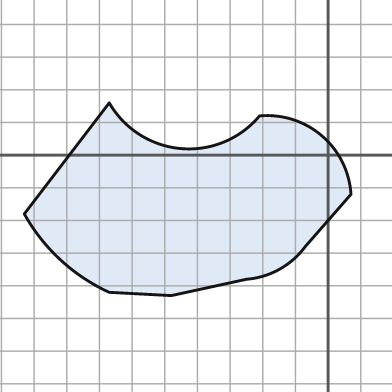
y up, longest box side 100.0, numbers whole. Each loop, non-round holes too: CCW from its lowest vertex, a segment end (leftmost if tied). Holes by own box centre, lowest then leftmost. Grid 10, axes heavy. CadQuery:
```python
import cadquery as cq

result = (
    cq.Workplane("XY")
    .moveTo(-48.0, -43.0)
    .lineTo(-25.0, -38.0)
    .threePointArc((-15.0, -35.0), (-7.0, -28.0))
    .lineTo(7.0, -12.0)
    .threePointArc((-2.0, 6.0), (-21.0, 12.0))
    .threePointArc((-45.0, 2.0), (-67.0, 16.0))
    .lineTo(-93.0, -18.0)
    .threePointArc((-82.0, -32.0), (-67.0, -42.0))
    .close()
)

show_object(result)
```